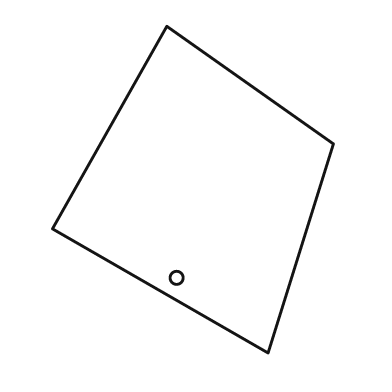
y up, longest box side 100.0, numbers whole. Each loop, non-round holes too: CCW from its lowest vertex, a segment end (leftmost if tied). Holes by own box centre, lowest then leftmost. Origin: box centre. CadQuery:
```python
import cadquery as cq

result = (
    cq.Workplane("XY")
    .moveTo(23.0, -50.0)
    .lineTo(43.0, 14.0)
    .lineTo(-8.0, 50.0)
    .lineTo(-43.0, -12.0)
    .close()
    .moveTo(-5.0, -27.0)
    .circle(2.0)
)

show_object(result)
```